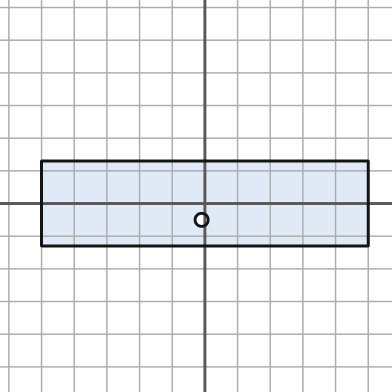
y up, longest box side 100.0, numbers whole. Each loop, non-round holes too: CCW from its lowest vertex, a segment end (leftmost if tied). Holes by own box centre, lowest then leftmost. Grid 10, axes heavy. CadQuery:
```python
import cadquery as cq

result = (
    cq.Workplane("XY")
    .moveTo(-50.0, -13.0)
    .lineTo(50.0, -13.0)
    .lineTo(50.0, 13.0)
    .lineTo(-50.0, 13.0)
    .close()
    .moveTo(-1.0, -5.0)
    .circle(2.0)
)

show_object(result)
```